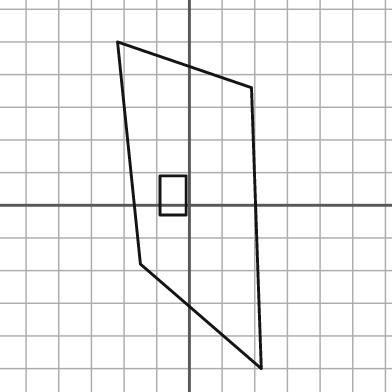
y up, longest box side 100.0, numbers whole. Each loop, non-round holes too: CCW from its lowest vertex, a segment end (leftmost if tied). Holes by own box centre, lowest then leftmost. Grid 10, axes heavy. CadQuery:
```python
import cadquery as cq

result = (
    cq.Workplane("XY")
    .moveTo(22.0, -50.0)
    .lineTo(19.0, 36.0)
    .lineTo(-22.0, 50.0)
    .lineTo(-15.0, -18.0)
    .close()
    .moveTo(-9.0, -3.0)
    .lineTo(-1.0, -3.0)
    .lineTo(-1.0, 9.0)
    .lineTo(-9.0, 9.0)
    .close()
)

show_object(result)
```